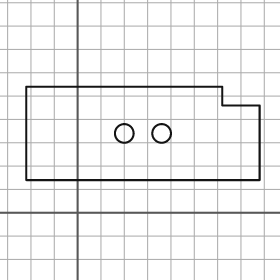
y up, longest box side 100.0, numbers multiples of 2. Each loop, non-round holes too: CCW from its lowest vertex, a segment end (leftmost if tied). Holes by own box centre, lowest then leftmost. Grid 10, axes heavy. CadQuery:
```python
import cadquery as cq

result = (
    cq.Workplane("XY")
    .moveTo(-22.0, 14.0)
    .lineTo(78.0, 14.0)
    .lineTo(78.0, 46.0)
    .lineTo(62.0, 46.0)
    .lineTo(62.0, 54.0)
    .lineTo(-22.0, 54.0)
    .close()
    .moveTo(20.0, 34.0)
    .circle(4.0)
    .moveTo(36.0, 34.0)
    .circle(4.0)
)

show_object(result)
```